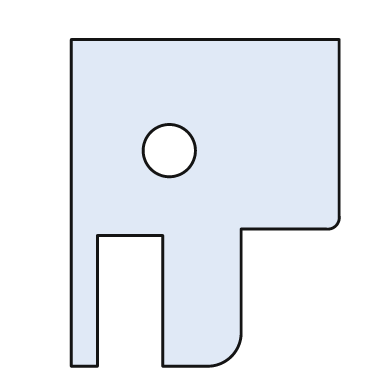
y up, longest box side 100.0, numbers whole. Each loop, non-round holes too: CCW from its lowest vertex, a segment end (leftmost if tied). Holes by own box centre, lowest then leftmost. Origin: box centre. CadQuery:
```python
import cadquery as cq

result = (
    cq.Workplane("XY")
    .moveTo(-41.0, -50.0)
    .lineTo(-33.0, -50.0)
    .lineTo(-33.0, -10.0)
    .lineTo(-13.0, -10.0)
    .lineTo(-13.0, -50.0)
    .lineTo(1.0, -50.0)
    .threePointArc((8.0, -47.0), (11.0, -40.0))
    .lineTo(11.0, -8.0)
    .lineTo(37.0, -8.0)
    .threePointArc((40.0, -7.0), (41.0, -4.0))
    .lineTo(41.0, 50.0)
    .lineTo(-41.0, 50.0)
    .close()
    .moveTo(-11.0, 16.0)
    .circle(8.0)
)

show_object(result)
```